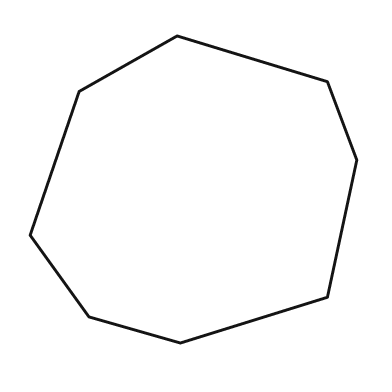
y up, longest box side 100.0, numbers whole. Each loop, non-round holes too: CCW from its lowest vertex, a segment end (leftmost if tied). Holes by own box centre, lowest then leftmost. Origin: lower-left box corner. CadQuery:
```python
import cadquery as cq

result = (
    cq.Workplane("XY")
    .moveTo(46.0, 0.0)
    .lineTo(91.0, 14.0)
    .lineTo(100.0, 56.0)
    .lineTo(91.0, 80.0)
    .lineTo(45.0, 94.0)
    .lineTo(15.0, 77.0)
    .lineTo(0.0, 33.0)
    .lineTo(18.0, 8.0)
    .close()
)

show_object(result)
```